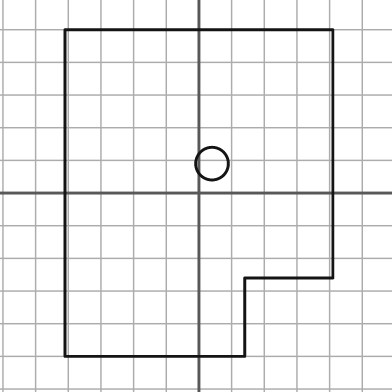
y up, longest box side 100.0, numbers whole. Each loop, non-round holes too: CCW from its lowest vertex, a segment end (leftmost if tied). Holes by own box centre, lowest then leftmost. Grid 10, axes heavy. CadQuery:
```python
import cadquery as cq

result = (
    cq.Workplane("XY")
    .moveTo(-41.0, -50.0)
    .lineTo(14.0, -50.0)
    .lineTo(14.0, -26.0)
    .lineTo(41.0, -26.0)
    .lineTo(41.0, 50.0)
    .lineTo(-41.0, 50.0)
    .close()
    .moveTo(4.0, 9.0)
    .circle(5.0)
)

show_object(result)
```